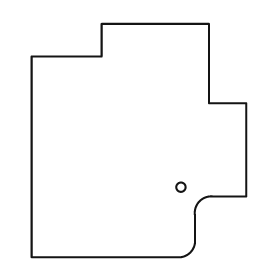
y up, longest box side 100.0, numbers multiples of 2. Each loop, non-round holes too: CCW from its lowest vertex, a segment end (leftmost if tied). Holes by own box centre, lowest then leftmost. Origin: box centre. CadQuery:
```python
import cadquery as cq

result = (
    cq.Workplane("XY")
    .moveTo(-46.0, -50.0)
    .lineTo(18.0, -50.0)
    .threePointArc((22.0, -48.0), (24.0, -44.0))
    .lineTo(24.0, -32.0)
    .threePointArc((26.0, -26.0), (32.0, -24.0))
    .lineTo(46.0, -24.0)
    .lineTo(46.0, 16.0)
    .lineTo(30.0, 16.0)
    .lineTo(30.0, 50.0)
    .lineTo(-16.0, 50.0)
    .lineTo(-16.0, 36.0)
    .lineTo(-46.0, 36.0)
    .close()
    .moveTo(18.0, -20.0)
    .circle(2.0)
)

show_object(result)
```